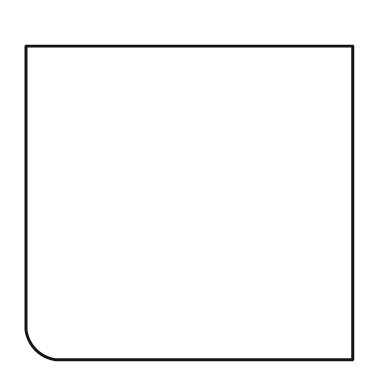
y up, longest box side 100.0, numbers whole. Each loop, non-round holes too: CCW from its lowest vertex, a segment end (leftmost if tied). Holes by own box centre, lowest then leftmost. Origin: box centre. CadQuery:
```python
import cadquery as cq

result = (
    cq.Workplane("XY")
    .moveTo(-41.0, -48.0)
    .lineTo(50.0, -48.0)
    .lineTo(50.0, 48.0)
    .lineTo(-50.0, 48.0)
    .lineTo(-50.0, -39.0)
    .threePointArc((-47.0, -45.0), (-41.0, -48.0))
    .close()
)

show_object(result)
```